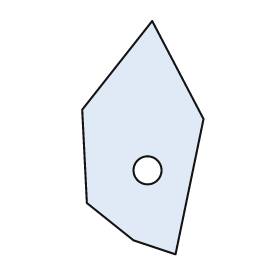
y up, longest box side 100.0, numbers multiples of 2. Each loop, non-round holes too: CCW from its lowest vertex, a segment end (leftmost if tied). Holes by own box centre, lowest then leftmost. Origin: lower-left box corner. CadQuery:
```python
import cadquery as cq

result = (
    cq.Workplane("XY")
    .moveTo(40.0, 0.0)
    .lineTo(52.0, 58.0)
    .lineTo(30.0, 100.0)
    .lineTo(0.0, 62.0)
    .lineTo(2.0, 22.0)
    .lineTo(22.0, 6.0)
    .close()
    .moveTo(28.0, 36.0)
    .circle(6.0)
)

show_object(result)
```